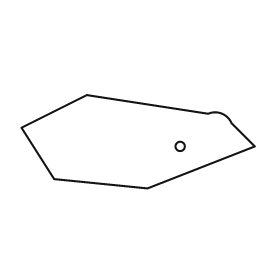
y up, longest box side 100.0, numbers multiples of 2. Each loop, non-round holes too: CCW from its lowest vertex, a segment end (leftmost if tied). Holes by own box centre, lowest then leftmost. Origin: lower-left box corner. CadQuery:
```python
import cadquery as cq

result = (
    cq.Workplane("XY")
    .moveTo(54.0, 0.0)
    .lineTo(100.0, 18.0)
    .lineTo(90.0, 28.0)
    .threePointArc((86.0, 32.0), (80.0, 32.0))
    .lineTo(28.0, 40.0)
    .lineTo(0.0, 26.0)
    .lineTo(14.0, 4.0)
    .close()
    .moveTo(68.0, 18.0)
    .circle(2.0)
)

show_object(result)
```